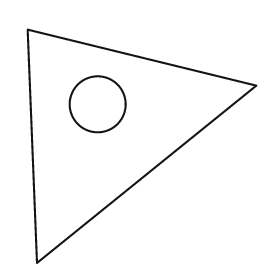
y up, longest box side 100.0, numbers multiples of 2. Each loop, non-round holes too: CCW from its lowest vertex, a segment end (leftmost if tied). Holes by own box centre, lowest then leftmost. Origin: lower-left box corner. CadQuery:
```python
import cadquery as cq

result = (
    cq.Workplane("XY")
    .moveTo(4.0, 0.0)
    .lineTo(98.0, 76.0)
    .lineTo(0.0, 100.0)
    .close()
    .moveTo(30.0, 68.0)
    .circle(12.0)
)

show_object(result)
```